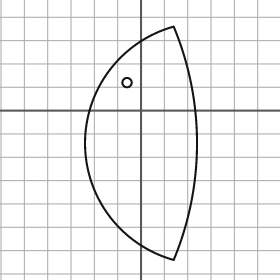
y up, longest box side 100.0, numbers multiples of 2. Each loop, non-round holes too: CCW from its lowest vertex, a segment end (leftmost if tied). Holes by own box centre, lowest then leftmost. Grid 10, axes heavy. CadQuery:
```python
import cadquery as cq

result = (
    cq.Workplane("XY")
    .moveTo(14.0, -64.0)
    .threePointArc((24.0, -14.0), (14.0, 36.0))
    .threePointArc((-24.0, -14.0), (14.0, -64.0))
    .close()
    .moveTo(-6.0, 12.0)
    .circle(2.0)
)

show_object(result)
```